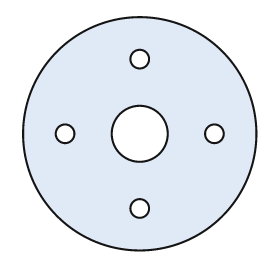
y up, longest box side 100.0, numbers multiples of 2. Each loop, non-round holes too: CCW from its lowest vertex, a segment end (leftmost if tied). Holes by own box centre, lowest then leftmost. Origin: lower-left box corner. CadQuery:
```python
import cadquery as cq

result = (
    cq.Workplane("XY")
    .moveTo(50.0, 50.0)
    .circle(50.0)
    .moveTo(50.0, 18.0)
    .circle(4.0)
    .moveTo(18.0, 50.0)
    .circle(4.0)
    .moveTo(50.0, 50.0)
    .circle(12.0)
    .moveTo(82.0, 50.0)
    .circle(4.0)
    .moveTo(50.0, 82.0)
    .circle(4.0)
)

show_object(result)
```